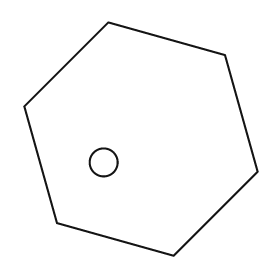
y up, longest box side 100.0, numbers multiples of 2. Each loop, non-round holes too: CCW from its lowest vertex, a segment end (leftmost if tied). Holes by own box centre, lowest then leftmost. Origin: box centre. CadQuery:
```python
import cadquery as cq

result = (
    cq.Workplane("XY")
    .moveTo(14.0, -50.0)
    .lineTo(50.0, -14.0)
    .lineTo(36.0, 36.0)
    .lineTo(-14.0, 50.0)
    .lineTo(-50.0, 14.0)
    .lineTo(-36.0, -36.0)
    .close()
    .moveTo(-16.0, -10.0)
    .circle(6.0)
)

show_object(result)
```